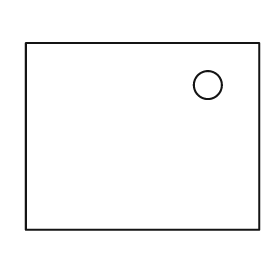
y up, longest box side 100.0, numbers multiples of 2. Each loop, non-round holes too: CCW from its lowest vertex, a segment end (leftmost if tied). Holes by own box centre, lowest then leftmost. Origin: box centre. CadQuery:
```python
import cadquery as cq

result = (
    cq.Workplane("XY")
    .moveTo(-50.0, -40.0)
    .lineTo(50.0, -40.0)
    .lineTo(50.0, 40.0)
    .lineTo(-50.0, 40.0)
    .close()
    .moveTo(28.0, 22.0)
    .circle(6.0)
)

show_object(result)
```